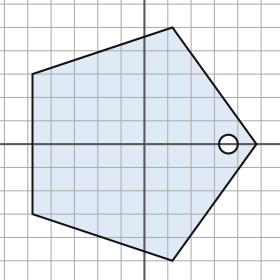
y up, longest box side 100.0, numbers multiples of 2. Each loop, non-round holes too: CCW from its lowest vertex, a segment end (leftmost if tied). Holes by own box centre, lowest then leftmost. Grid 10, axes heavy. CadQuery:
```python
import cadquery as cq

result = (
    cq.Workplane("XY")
    .moveTo(12.0, -50.0)
    .lineTo(48.0, 0.0)
    .lineTo(12.0, 50.0)
    .lineTo(-48.0, 30.0)
    .lineTo(-48.0, -30.0)
    .close()
    .moveTo(36.0, 0.0)
    .circle(4.0)
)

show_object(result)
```